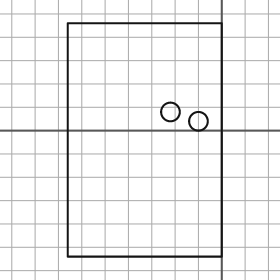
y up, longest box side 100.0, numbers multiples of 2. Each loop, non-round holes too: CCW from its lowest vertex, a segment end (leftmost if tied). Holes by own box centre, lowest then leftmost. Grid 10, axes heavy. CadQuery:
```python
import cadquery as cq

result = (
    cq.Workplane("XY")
    .moveTo(-66.0, -54.0)
    .lineTo(0.0, -54.0)
    .lineTo(0.0, 46.0)
    .lineTo(-66.0, 46.0)
    .close()
    .moveTo(-10.0, 4.0)
    .circle(4.0)
    .moveTo(-22.0, 8.0)
    .circle(4.0)
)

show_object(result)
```